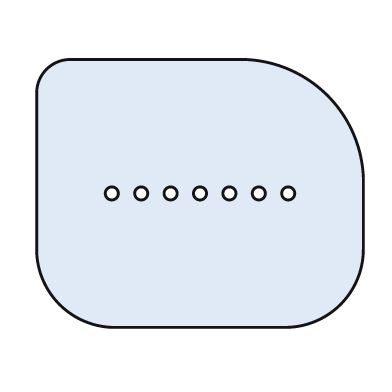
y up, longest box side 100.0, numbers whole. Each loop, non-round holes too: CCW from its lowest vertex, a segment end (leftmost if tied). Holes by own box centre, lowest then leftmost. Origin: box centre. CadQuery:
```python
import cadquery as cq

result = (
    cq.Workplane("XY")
    .moveTo(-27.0, -41.0)
    .lineTo(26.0, -41.0)
    .threePointArc((43.0, -34.0), (50.0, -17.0))
    .lineTo(50.0, 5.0)
    .threePointArc((39.0, 30.0), (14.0, 41.0))
    .lineTo(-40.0, 41.0)
    .threePointArc((-47.0, 38.0), (-50.0, 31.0))
    .lineTo(-50.0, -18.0)
    .threePointArc((-43.0, -34.0), (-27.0, -41.0))
    .close()
    .moveTo(-27.0, 0.0)
    .circle(2.0)
    .moveTo(-18.0, 0.0)
    .circle(2.0)
    .moveTo(-9.0, 0.0)
    .circle(2.0)
    .moveTo(0.0, 0.0)
    .circle(2.0)
    .moveTo(9.0, 0.0)
    .circle(2.0)
    .moveTo(18.0, 0.0)
    .circle(2.0)
    .moveTo(27.0, 0.0)
    .circle(2.0)
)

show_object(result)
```